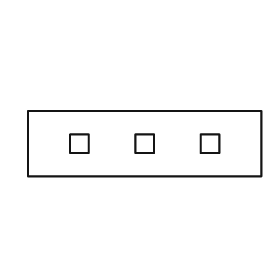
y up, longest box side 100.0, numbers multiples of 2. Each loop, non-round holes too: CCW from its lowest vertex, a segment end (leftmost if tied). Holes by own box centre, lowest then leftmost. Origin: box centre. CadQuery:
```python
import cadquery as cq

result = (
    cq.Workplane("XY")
    .moveTo(-50.0, -14.0)
    .lineTo(50.0, -14.0)
    .lineTo(50.0, 14.0)
    .lineTo(-50.0, 14.0)
    .close()
    .moveTo(-32.0, -4.0)
    .lineTo(-24.0, -4.0)
    .lineTo(-24.0, 4.0)
    .lineTo(-32.0, 4.0)
    .close()
    .moveTo(-4.0, -4.0)
    .lineTo(4.0, -4.0)
    .lineTo(4.0, 4.0)
    .lineTo(-4.0, 4.0)
    .close()
    .moveTo(24.0, -4.0)
    .lineTo(32.0, -4.0)
    .lineTo(32.0, 4.0)
    .lineTo(24.0, 4.0)
    .close()
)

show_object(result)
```